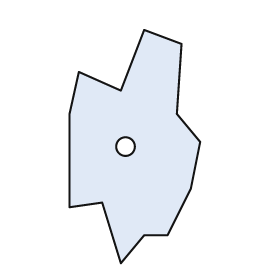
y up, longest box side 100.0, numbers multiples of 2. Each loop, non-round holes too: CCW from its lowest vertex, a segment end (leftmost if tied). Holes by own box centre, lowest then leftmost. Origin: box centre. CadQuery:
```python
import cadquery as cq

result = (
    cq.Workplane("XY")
    .moveTo(-6.0, -50.0)
    .lineTo(4.0, -38.0)
    .lineTo(14.0, -38.0)
    .lineTo(24.0, -18.0)
    .lineTo(28.0, 2.0)
    .lineTo(18.0, 14.0)
    .lineTo(20.0, 44.0)
    .lineTo(4.0, 50.0)
    .lineTo(-6.0, 24.0)
    .lineTo(-24.0, 32.0)
    .lineTo(-28.0, 14.0)
    .lineTo(-28.0, -26.0)
    .lineTo(-14.0, -24.0)
    .close()
    .moveTo(-4.0, 0.0)
    .circle(4.0)
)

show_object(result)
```